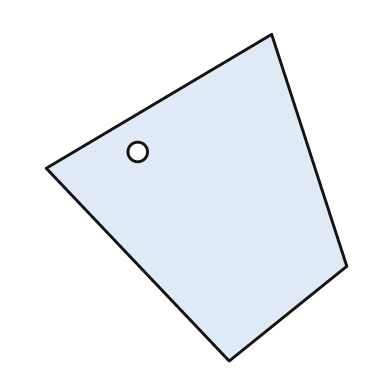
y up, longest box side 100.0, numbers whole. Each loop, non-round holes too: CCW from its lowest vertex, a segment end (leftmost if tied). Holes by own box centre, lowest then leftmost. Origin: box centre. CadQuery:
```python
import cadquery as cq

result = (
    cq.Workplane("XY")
    .moveTo(10.0, -50.0)
    .lineTo(46.0, -21.0)
    .lineTo(23.0, 50.0)
    .lineTo(-46.0, 9.0)
    .close()
    .moveTo(-18.0, 14.0)
    .circle(3.0)
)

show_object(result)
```